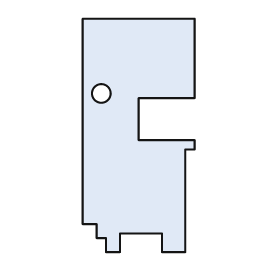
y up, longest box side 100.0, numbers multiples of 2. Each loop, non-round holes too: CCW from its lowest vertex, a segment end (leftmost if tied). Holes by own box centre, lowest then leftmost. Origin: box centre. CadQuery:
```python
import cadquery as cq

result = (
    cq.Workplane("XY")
    .moveTo(-14.0, -50.0)
    .lineTo(-8.0, -50.0)
    .lineTo(-8.0, -42.0)
    .lineTo(10.0, -42.0)
    .lineTo(10.0, -50.0)
    .lineTo(20.0, -50.0)
    .lineTo(20.0, -6.0)
    .lineTo(24.0, -6.0)
    .lineTo(24.0, -2.0)
    .lineTo(0.0, -2.0)
    .lineTo(0.0, 16.0)
    .lineTo(24.0, 16.0)
    .lineTo(24.0, 50.0)
    .lineTo(-24.0, 50.0)
    .lineTo(-24.0, -38.0)
    .lineTo(-18.0, -38.0)
    .lineTo(-18.0, -44.0)
    .lineTo(-14.0, -44.0)
    .close()
    .moveTo(-16.0, 18.0)
    .circle(4.0)
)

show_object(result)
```